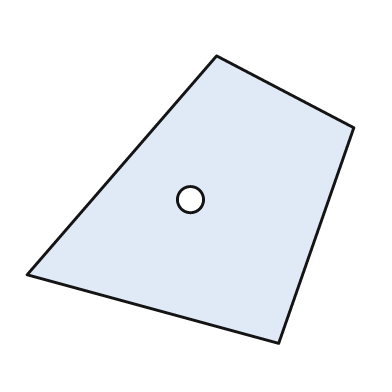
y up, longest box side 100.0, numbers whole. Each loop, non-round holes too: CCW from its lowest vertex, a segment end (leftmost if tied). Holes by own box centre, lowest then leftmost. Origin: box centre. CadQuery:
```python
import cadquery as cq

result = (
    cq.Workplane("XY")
    .moveTo(27.0, -44.0)
    .lineTo(50.0, 22.0)
    .lineTo(8.0, 44.0)
    .lineTo(-50.0, -23.0)
    .close()
    .moveTo(0.0, 0.0)
    .circle(4.0)
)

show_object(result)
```